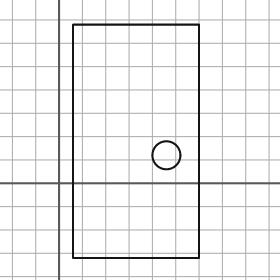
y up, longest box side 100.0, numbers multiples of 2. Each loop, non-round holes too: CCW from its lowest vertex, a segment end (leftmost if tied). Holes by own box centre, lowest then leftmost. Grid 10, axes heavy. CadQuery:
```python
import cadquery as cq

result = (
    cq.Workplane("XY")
    .moveTo(6.0, -32.0)
    .lineTo(60.0, -32.0)
    .lineTo(60.0, 68.0)
    .lineTo(6.0, 68.0)
    .close()
    .moveTo(46.0, 12.0)
    .circle(6.0)
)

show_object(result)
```